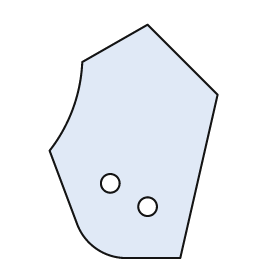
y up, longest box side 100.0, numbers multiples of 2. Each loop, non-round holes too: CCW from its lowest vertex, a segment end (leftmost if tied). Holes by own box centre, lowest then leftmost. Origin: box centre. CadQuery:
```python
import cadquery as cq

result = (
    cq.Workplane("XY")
    .moveTo(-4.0, -50.0)
    .lineTo(20.0, -50.0)
    .lineTo(36.0, 20.0)
    .lineTo(6.0, 50.0)
    .lineTo(-22.0, 34.0)
    .threePointArc((-26.0, 14.0), (-36.0, -4.0))
    .lineTo(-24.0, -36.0)
    .threePointArc((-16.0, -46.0), (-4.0, -50.0))
    .close()
    .moveTo(6.0, -28.0)
    .circle(4.0)
    .moveTo(-10.0, -18.0)
    .circle(4.0)
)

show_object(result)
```